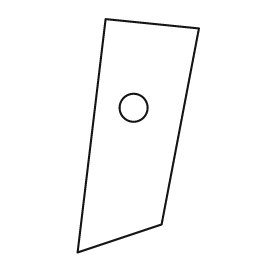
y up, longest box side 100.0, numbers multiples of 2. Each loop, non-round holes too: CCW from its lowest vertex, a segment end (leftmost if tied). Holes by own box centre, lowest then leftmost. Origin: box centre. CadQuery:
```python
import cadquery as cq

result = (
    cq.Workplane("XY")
    .moveTo(-26.0, -50.0)
    .lineTo(10.0, -38.0)
    .lineTo(26.0, 46.0)
    .lineTo(-14.0, 50.0)
    .close()
    .moveTo(-2.0, 12.0)
    .circle(6.0)
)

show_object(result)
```